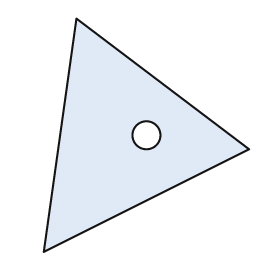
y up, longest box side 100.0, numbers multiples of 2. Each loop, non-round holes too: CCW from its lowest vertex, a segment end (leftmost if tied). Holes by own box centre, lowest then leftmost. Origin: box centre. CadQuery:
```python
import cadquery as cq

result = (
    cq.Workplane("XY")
    .moveTo(-44.0, -50.0)
    .lineTo(44.0, -6.0)
    .lineTo(-30.0, 50.0)
    .close()
    .moveTo(0.0, 0.0)
    .circle(6.0)
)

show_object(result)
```